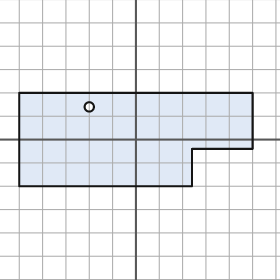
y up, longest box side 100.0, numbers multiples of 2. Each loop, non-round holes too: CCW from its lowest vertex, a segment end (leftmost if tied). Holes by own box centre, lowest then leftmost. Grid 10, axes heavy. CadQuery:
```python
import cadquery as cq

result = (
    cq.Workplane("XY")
    .moveTo(-50.0, -20.0)
    .lineTo(24.0, -20.0)
    .lineTo(24.0, -4.0)
    .lineTo(50.0, -4.0)
    .lineTo(50.0, 20.0)
    .lineTo(-50.0, 20.0)
    .close()
    .moveTo(-20.0, 14.0)
    .circle(2.0)
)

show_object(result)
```